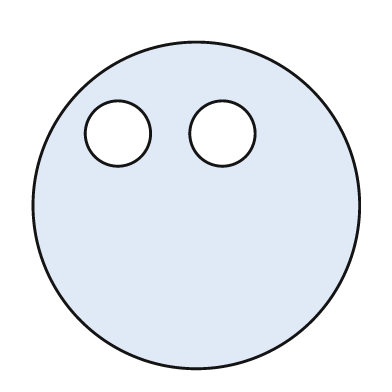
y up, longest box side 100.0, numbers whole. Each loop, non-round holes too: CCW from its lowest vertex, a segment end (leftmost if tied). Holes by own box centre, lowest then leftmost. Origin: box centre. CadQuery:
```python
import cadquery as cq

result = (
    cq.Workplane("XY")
    .moveTo(0.0, 0.0)
    .circle(50.0)
    .moveTo(-24.0, 22.0)
    .circle(10.0)
    .moveTo(8.0, 22.0)
    .circle(10.0)
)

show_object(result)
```